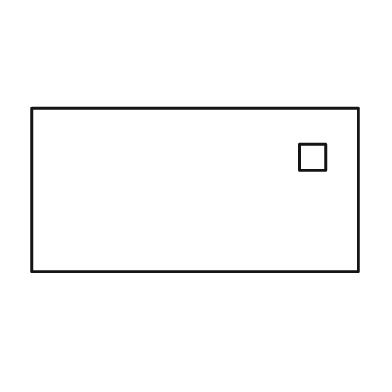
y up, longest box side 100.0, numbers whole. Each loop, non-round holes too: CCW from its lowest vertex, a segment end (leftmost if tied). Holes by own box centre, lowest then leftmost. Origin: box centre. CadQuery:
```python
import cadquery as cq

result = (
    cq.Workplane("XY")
    .moveTo(-50.0, -25.0)
    .lineTo(50.0, -25.0)
    .lineTo(50.0, 25.0)
    .lineTo(-50.0, 25.0)
    .close()
    .moveTo(32.0, 6.0)
    .lineTo(40.0, 6.0)
    .lineTo(40.0, 14.0)
    .lineTo(32.0, 14.0)
    .close()
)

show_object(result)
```